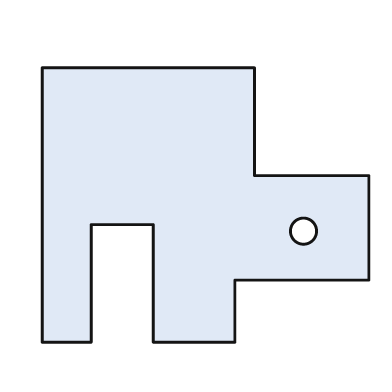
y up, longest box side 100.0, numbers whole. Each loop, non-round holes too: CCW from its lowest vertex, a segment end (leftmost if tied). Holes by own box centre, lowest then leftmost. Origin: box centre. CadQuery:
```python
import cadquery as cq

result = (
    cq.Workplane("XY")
    .moveTo(-50.0, -42.0)
    .lineTo(-35.0, -42.0)
    .lineTo(-35.0, -6.0)
    .lineTo(-16.0, -6.0)
    .lineTo(-16.0, -42.0)
    .lineTo(9.0, -42.0)
    .lineTo(9.0, -23.0)
    .lineTo(50.0, -23.0)
    .lineTo(50.0, 9.0)
    .lineTo(15.0, 9.0)
    .lineTo(15.0, 42.0)
    .lineTo(-50.0, 42.0)
    .close()
    .moveTo(30.0, -8.0)
    .circle(4.0)
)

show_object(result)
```